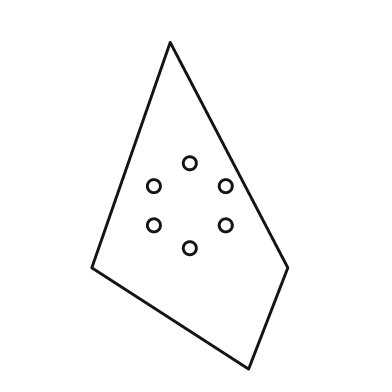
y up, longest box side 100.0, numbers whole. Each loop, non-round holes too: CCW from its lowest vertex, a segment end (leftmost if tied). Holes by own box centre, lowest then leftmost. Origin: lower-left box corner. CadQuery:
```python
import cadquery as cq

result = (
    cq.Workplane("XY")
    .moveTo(48.0, 0.0)
    .lineTo(60.0, 31.0)
    .lineTo(24.0, 100.0)
    .lineTo(0.0, 31.0)
    .close()
    .moveTo(30.0, 37.0)
    .circle(2.0)
    .moveTo(19.0, 44.0)
    .circle(2.0)
    .moveTo(41.0, 44.0)
    .circle(2.0)
    .moveTo(19.0, 56.0)
    .circle(2.0)
    .moveTo(41.0, 56.0)
    .circle(2.0)
    .moveTo(30.0, 63.0)
    .circle(2.0)
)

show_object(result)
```